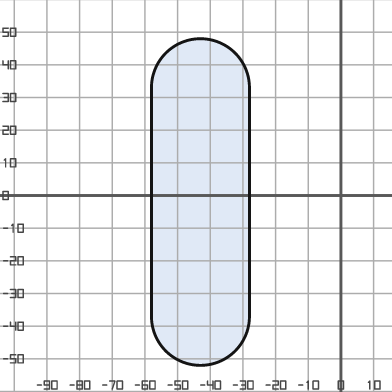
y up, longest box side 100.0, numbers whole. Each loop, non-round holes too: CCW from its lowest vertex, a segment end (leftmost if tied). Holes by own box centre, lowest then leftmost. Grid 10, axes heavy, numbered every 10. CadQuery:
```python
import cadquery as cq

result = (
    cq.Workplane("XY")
    .moveTo(-58.0, -37.0)
    .threePointArc((-43.0, -52.0), (-28.0, -37.0))
    .lineTo(-28.0, 33.0)
    .threePointArc((-43.0, 48.0), (-58.0, 33.0))
    .close()
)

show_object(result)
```